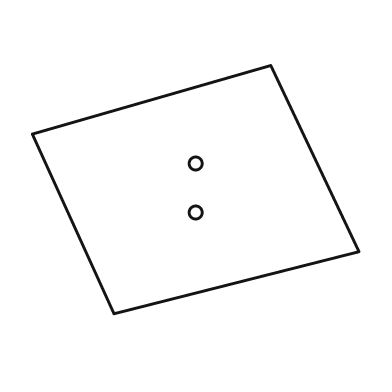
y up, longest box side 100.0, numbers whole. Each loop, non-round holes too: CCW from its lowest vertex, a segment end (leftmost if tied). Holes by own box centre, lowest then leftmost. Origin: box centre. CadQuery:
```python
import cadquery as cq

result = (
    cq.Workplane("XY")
    .moveTo(-25.0, -38.0)
    .lineTo(50.0, -19.0)
    .lineTo(23.0, 38.0)
    .lineTo(-50.0, 17.0)
    .close()
    .moveTo(0.0, -7.0)
    .circle(2.0)
    .moveTo(0.0, 8.0)
    .circle(2.0)
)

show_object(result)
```